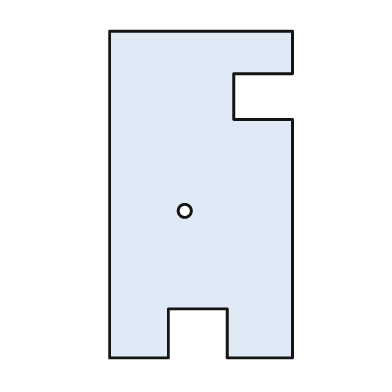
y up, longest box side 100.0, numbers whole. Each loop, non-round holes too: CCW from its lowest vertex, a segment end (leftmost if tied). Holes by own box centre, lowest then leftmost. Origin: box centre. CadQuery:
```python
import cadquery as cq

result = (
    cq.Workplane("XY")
    .moveTo(-28.0, -50.0)
    .lineTo(-10.0, -50.0)
    .lineTo(-10.0, -35.0)
    .lineTo(8.0, -35.0)
    .lineTo(8.0, -50.0)
    .lineTo(28.0, -50.0)
    .lineTo(28.0, 23.0)
    .lineTo(10.0, 23.0)
    .lineTo(10.0, 37.0)
    .lineTo(28.0, 37.0)
    .lineTo(28.0, 50.0)
    .lineTo(-28.0, 50.0)
    .close()
    .moveTo(-5.0, -5.0)
    .circle(2.0)
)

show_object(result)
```